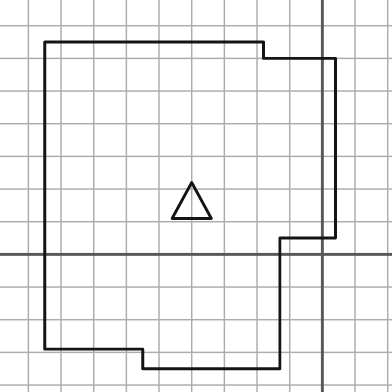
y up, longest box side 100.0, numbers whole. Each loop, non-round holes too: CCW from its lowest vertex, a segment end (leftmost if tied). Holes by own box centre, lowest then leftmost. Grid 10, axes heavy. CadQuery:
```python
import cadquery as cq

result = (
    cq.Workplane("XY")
    .moveTo(-55.0, -35.0)
    .lineTo(-13.0, -35.0)
    .lineTo(-13.0, 5.0)
    .lineTo(4.0, 5.0)
    .lineTo(4.0, 60.0)
    .lineTo(-18.0, 60.0)
    .lineTo(-18.0, 65.0)
    .lineTo(-85.0, 65.0)
    .lineTo(-85.0, -29.0)
    .lineTo(-55.0, -29.0)
    .close()
    .moveTo(-46.0, 11.0)
    .lineTo(-34.0, 11.0)
    .lineTo(-40.0, 22.0)
    .close()
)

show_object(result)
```